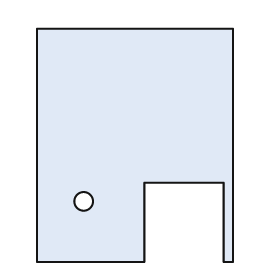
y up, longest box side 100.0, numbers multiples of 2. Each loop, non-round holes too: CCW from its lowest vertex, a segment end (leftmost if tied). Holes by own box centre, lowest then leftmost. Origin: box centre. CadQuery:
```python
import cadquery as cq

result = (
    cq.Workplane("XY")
    .moveTo(-42.0, -50.0)
    .lineTo(4.0, -50.0)
    .lineTo(4.0, -16.0)
    .lineTo(38.0, -16.0)
    .lineTo(38.0, -50.0)
    .lineTo(42.0, -50.0)
    .lineTo(42.0, 50.0)
    .lineTo(-42.0, 50.0)
    .close()
    .moveTo(-22.0, -24.0)
    .circle(4.0)
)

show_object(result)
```